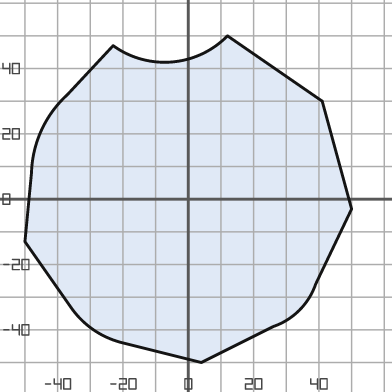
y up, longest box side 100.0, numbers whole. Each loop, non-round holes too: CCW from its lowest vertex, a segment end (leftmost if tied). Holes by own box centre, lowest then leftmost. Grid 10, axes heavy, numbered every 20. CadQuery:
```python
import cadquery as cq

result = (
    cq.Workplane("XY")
    .moveTo(4.0, -50.0)
    .lineTo(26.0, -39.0)
    .threePointArc((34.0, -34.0), (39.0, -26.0))
    .lineTo(50.0, -3.0)
    .lineTo(41.0, 30.0)
    .lineTo(12.0, 50.0)
    .threePointArc((-5.0, 42.0), (-23.0, 47.0))
    .lineTo(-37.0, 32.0)
    .threePointArc((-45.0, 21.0), (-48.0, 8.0))
    .lineTo(-50.0, -13.0)
    .lineTo(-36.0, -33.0)
    .threePointArc((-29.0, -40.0), (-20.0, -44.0))
    .close()
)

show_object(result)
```